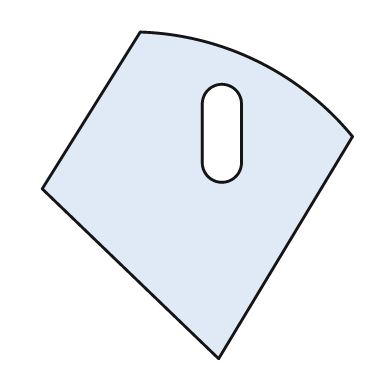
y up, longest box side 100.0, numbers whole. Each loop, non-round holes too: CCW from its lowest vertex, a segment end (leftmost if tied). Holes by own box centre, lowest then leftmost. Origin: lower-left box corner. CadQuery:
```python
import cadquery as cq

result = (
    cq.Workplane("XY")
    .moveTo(54.0, 0.0)
    .lineTo(95.0, 68.0)
    .threePointArc((66.0, 91.0), (30.0, 100.0))
    .lineTo(0.0, 52.0)
    .close()
    .moveTo(49.0, 60.0)
    .threePointArc((55.0, 54.0), (61.0, 60.0))
    .lineTo(61.0, 78.0)
    .threePointArc((55.0, 84.0), (49.0, 78.0))
    .close()
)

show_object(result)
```